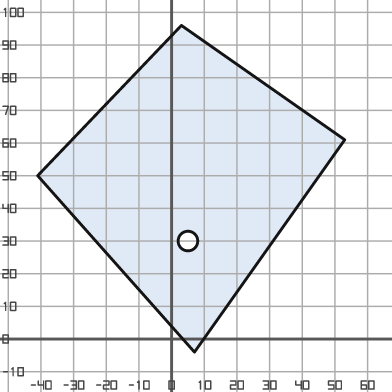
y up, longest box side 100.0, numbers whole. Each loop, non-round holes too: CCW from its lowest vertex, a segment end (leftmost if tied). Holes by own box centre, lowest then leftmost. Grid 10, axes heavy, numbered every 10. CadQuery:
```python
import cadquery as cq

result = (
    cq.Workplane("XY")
    .moveTo(7.0, -4.0)
    .lineTo(53.0, 61.0)
    .lineTo(3.0, 96.0)
    .lineTo(-41.0, 50.0)
    .close()
    .moveTo(5.0, 30.0)
    .circle(3.0)
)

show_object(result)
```